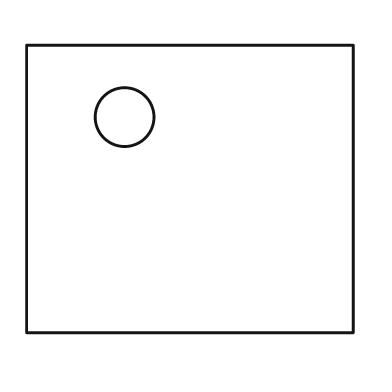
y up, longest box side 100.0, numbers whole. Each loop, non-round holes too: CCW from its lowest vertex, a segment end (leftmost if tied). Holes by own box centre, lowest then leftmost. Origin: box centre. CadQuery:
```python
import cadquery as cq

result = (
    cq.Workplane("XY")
    .moveTo(-50.0, -44.0)
    .lineTo(50.0, -44.0)
    .lineTo(50.0, 44.0)
    .lineTo(-50.0, 44.0)
    .close()
    .moveTo(-20.0, 22.0)
    .circle(9.0)
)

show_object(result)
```